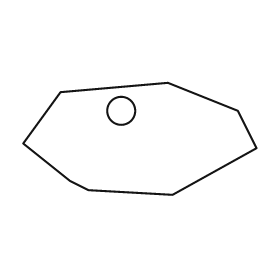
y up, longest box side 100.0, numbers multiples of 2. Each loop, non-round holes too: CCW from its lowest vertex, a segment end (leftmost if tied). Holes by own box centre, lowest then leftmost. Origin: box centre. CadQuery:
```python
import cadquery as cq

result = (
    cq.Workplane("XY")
    .moveTo(14.0, -24.0)
    .lineTo(50.0, -4.0)
    .lineTo(42.0, 12.0)
    .lineTo(12.0, 24.0)
    .lineTo(-34.0, 20.0)
    .lineTo(-50.0, -2.0)
    .lineTo(-30.0, -18.0)
    .lineTo(-22.0, -22.0)
    .close()
    .moveTo(-8.0, 12.0)
    .circle(6.0)
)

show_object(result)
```